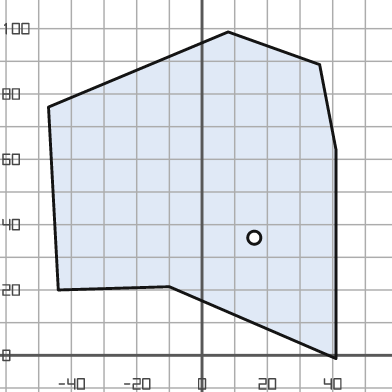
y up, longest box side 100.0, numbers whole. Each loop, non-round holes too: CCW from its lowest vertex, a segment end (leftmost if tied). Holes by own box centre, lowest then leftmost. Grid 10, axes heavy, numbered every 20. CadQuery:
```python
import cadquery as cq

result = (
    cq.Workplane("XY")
    .moveTo(41.0, -1.0)
    .lineTo(41.0, 63.0)
    .lineTo(36.0, 89.0)
    .lineTo(8.0, 99.0)
    .lineTo(-47.0, 76.0)
    .lineTo(-44.0, 20.0)
    .lineTo(-10.0, 21.0)
    .close()
    .moveTo(16.0, 36.0)
    .circle(2.0)
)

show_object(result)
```